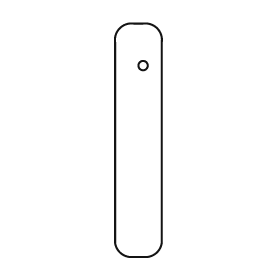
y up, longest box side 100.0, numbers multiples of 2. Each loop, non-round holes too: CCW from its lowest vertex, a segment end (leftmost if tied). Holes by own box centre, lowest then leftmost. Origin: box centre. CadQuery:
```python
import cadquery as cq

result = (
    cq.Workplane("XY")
    .moveTo(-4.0, -50.0)
    .lineTo(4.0, -50.0)
    .threePointArc((8.0, -48.0), (10.0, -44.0))
    .lineTo(10.0, 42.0)
    .threePointArc((8.0, 48.0), (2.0, 50.0))
    .lineTo(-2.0, 50.0)
    .threePointArc((-8.0, 48.0), (-10.0, 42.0))
    .lineTo(-10.0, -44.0)
    .threePointArc((-8.0, -48.0), (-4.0, -50.0))
    .close()
    .moveTo(2.0, 32.0)
    .circle(2.0)
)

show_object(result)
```